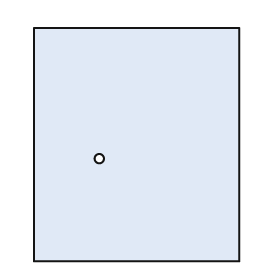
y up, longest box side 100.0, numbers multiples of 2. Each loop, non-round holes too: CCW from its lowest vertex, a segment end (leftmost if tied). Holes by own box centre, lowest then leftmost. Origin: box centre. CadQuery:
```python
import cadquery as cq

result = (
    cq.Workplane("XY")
    .moveTo(-44.0, -50.0)
    .lineTo(44.0, -50.0)
    .lineTo(44.0, 50.0)
    .lineTo(-44.0, 50.0)
    .close()
    .moveTo(-16.0, -6.0)
    .circle(2.0)
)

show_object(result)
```